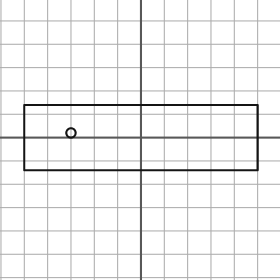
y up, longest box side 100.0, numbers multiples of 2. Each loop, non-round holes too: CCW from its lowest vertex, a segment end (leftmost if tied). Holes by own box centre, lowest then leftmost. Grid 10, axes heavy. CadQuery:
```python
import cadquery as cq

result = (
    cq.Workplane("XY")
    .moveTo(-50.0, -14.0)
    .lineTo(50.0, -14.0)
    .lineTo(50.0, 14.0)
    .lineTo(-50.0, 14.0)
    .close()
    .moveTo(-30.0, 2.0)
    .circle(2.0)
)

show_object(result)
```